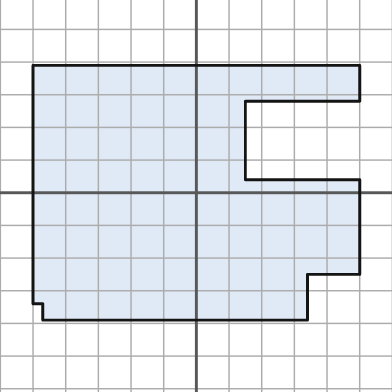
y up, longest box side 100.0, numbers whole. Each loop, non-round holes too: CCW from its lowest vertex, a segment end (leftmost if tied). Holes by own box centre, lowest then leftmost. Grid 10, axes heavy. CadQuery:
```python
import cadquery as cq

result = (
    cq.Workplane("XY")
    .moveTo(-47.0, -39.0)
    .lineTo(34.0, -39.0)
    .lineTo(34.0, -25.0)
    .lineTo(50.0, -25.0)
    .lineTo(50.0, 4.0)
    .lineTo(15.0, 4.0)
    .lineTo(15.0, 28.0)
    .lineTo(50.0, 28.0)
    .lineTo(50.0, 39.0)
    .lineTo(-50.0, 39.0)
    .lineTo(-50.0, -34.0)
    .lineTo(-47.0, -34.0)
    .close()
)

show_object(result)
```